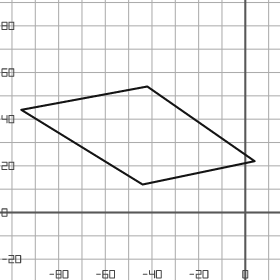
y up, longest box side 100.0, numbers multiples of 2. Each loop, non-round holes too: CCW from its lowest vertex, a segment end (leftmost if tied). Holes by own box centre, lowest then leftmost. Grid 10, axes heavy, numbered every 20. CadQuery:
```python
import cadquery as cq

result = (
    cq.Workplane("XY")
    .moveTo(-44.0, 12.0)
    .lineTo(4.0, 22.0)
    .lineTo(-42.0, 54.0)
    .lineTo(-96.0, 44.0)
    .close()
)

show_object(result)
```